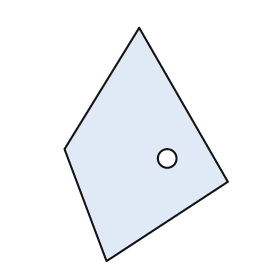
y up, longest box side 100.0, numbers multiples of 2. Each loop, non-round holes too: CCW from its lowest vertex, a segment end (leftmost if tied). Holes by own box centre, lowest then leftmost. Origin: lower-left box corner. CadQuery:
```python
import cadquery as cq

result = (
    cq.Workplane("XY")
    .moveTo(18.0, 0.0)
    .lineTo(70.0, 34.0)
    .lineTo(32.0, 100.0)
    .lineTo(0.0, 48.0)
    .close()
    .moveTo(44.0, 44.0)
    .circle(4.0)
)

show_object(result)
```